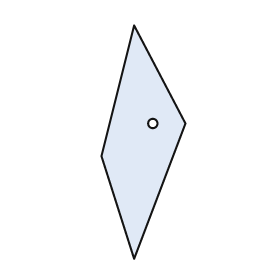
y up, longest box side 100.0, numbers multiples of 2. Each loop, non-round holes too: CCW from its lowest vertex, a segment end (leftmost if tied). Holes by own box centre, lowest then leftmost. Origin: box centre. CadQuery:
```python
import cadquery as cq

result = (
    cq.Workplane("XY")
    .moveTo(-4.0, -50.0)
    .lineTo(18.0, 8.0)
    .lineTo(-4.0, 50.0)
    .lineTo(-18.0, -6.0)
    .close()
    .moveTo(4.0, 8.0)
    .circle(2.0)
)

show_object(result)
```